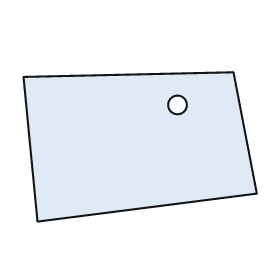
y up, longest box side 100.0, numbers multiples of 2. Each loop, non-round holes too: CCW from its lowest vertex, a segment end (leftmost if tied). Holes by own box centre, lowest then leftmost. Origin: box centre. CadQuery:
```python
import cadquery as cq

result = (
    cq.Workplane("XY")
    .moveTo(-44.0, -32.0)
    .lineTo(50.0, -20.0)
    .lineTo(40.0, 32.0)
    .lineTo(-50.0, 30.0)
    .close()
    .moveTo(16.0, 18.0)
    .circle(4.0)
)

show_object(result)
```